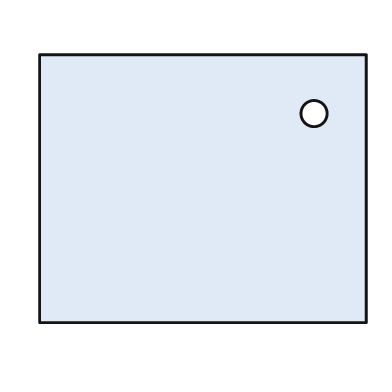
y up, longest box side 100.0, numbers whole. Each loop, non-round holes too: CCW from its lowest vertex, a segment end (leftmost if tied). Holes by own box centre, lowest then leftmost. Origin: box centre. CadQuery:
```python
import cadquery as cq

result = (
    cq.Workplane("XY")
    .moveTo(-50.0, -41.0)
    .lineTo(50.0, -41.0)
    .lineTo(50.0, 41.0)
    .lineTo(-50.0, 41.0)
    .close()
    .moveTo(34.0, 23.0)
    .circle(4.0)
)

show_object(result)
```